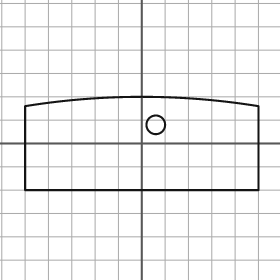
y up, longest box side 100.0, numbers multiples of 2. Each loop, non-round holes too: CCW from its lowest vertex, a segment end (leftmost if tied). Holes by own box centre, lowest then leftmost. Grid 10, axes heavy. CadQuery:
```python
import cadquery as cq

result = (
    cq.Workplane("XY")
    .moveTo(-50.0, -20.0)
    .lineTo(50.0, -20.0)
    .lineTo(50.0, 16.0)
    .threePointArc((0.0, 20.0), (-50.0, 16.0))
    .close()
    .moveTo(6.0, 8.0)
    .circle(4.0)
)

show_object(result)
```